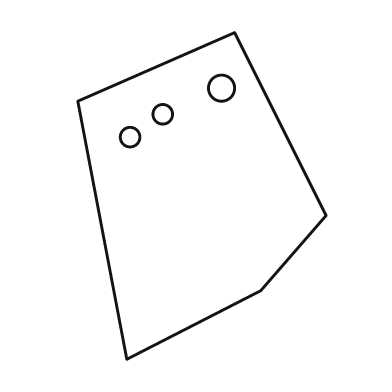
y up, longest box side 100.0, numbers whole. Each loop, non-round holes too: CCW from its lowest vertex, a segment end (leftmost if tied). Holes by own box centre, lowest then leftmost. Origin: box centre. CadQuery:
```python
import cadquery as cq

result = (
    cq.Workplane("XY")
    .moveTo(-23.0, -50.0)
    .lineTo(18.0, -29.0)
    .lineTo(38.0, -6.0)
    .lineTo(10.0, 50.0)
    .lineTo(-38.0, 29.0)
    .close()
    .moveTo(-22.0, 18.0)
    .circle(3.0)
    .moveTo(-12.0, 25.0)
    .circle(3.0)
    .moveTo(6.0, 33.0)
    .circle(4.0)
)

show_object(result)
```